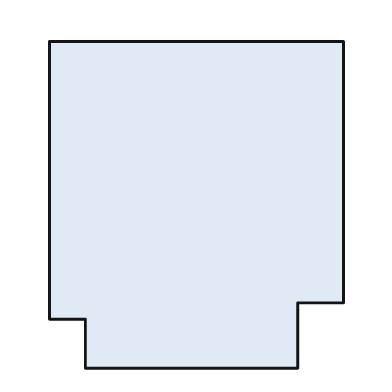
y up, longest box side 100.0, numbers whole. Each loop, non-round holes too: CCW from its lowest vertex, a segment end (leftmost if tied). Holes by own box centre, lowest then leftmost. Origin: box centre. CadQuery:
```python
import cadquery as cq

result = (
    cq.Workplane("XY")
    .moveTo(-34.0, -50.0)
    .lineTo(31.0, -50.0)
    .lineTo(31.0, -30.0)
    .lineTo(45.0, -30.0)
    .lineTo(45.0, 50.0)
    .lineTo(-45.0, 50.0)
    .lineTo(-45.0, -35.0)
    .lineTo(-34.0, -35.0)
    .close()
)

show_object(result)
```